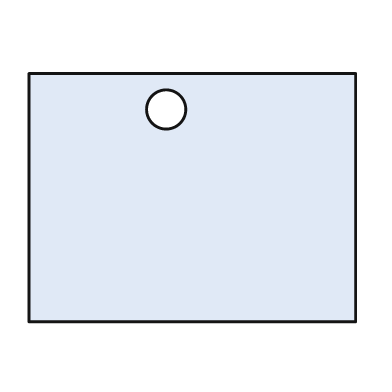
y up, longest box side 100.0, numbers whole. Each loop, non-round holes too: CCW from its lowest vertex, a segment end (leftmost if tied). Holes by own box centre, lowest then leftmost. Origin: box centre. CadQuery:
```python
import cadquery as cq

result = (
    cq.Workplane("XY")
    .moveTo(-50.0, -38.0)
    .lineTo(50.0, -38.0)
    .lineTo(50.0, 38.0)
    .lineTo(-50.0, 38.0)
    .close()
    .moveTo(-8.0, 27.0)
    .circle(6.0)
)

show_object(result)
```